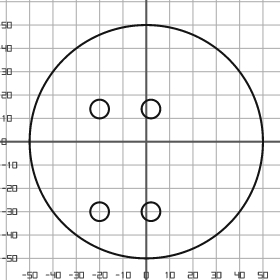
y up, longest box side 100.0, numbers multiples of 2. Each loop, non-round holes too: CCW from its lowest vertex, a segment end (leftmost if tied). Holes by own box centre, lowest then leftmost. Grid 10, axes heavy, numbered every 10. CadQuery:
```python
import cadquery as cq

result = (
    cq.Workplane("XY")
    .moveTo(0.0, 0.0)
    .circle(50.0)
    .moveTo(-20.0, -30.0)
    .circle(4.0)
    .moveTo(2.0, -30.0)
    .circle(4.0)
    .moveTo(-20.0, 14.0)
    .circle(4.0)
    .moveTo(2.0, 14.0)
    .circle(4.0)
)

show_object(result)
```